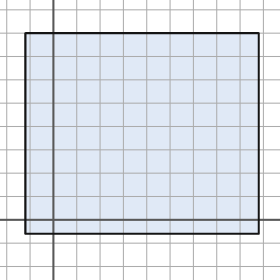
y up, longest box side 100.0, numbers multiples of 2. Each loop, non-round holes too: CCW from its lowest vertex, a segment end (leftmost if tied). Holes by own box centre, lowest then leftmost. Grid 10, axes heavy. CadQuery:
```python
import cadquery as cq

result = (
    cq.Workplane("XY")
    .moveTo(-12.0, -6.0)
    .lineTo(88.0, -6.0)
    .lineTo(88.0, 80.0)
    .lineTo(-12.0, 80.0)
    .close()
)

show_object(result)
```